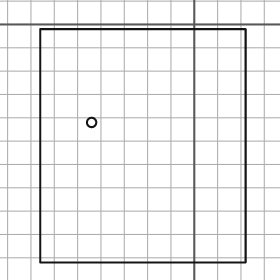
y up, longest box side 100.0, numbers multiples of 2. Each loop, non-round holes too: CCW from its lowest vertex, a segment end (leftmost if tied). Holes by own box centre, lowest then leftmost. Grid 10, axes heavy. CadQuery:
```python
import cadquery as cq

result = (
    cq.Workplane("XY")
    .moveTo(-66.0, -102.0)
    .lineTo(22.0, -102.0)
    .lineTo(22.0, -2.0)
    .lineTo(-66.0, -2.0)
    .close()
    .moveTo(-44.0, -42.0)
    .circle(2.0)
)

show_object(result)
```